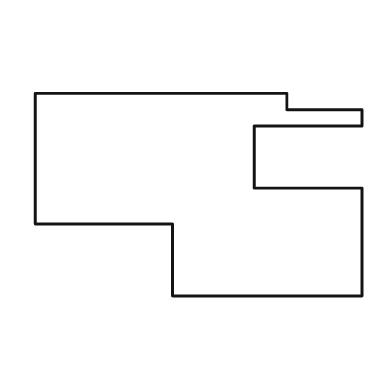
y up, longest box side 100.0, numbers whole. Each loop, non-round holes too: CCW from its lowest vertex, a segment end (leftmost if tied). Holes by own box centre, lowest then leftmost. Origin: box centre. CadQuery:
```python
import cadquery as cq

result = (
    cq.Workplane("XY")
    .moveTo(-8.0, -31.0)
    .lineTo(50.0, -31.0)
    .lineTo(50.0, 2.0)
    .lineTo(17.0, 2.0)
    .lineTo(17.0, 21.0)
    .lineTo(50.0, 21.0)
    .lineTo(50.0, 26.0)
    .lineTo(27.0, 26.0)
    .lineTo(27.0, 31.0)
    .lineTo(-50.0, 31.0)
    .lineTo(-50.0, -9.0)
    .lineTo(-8.0, -9.0)
    .close()
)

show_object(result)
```